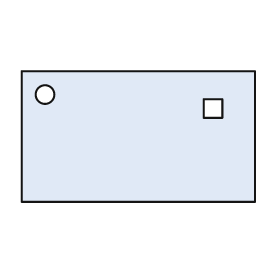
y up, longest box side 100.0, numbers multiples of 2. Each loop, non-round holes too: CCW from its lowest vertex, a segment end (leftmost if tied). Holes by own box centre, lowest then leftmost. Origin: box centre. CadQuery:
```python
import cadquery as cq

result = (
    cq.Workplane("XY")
    .moveTo(-50.0, -28.0)
    .lineTo(50.0, -28.0)
    .lineTo(50.0, 28.0)
    .lineTo(-50.0, 28.0)
    .close()
    .moveTo(28.0, 8.0)
    .lineTo(36.0, 8.0)
    .lineTo(36.0, 16.0)
    .lineTo(28.0, 16.0)
    .close()
    .moveTo(-40.0, 18.0)
    .circle(4.0)
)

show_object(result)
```